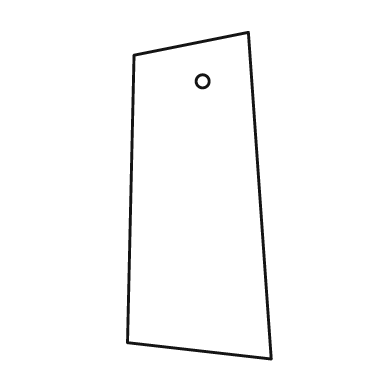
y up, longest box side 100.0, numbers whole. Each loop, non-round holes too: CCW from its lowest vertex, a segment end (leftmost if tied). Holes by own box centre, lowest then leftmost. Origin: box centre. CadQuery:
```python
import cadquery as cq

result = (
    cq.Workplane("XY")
    .moveTo(22.0, -50.0)
    .lineTo(15.0, 50.0)
    .lineTo(-20.0, 43.0)
    .lineTo(-22.0, -45.0)
    .close()
    .moveTo(1.0, 35.0)
    .circle(2.0)
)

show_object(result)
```